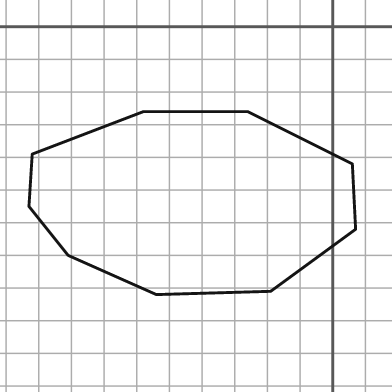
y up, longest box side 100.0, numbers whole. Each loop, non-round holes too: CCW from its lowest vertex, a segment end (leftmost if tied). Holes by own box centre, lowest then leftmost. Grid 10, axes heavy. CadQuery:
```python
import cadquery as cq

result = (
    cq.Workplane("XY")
    .moveTo(-54.0, -82.0)
    .lineTo(-19.0, -81.0)
    .lineTo(7.0, -62.0)
    .lineTo(6.0, -42.0)
    .lineTo(-26.0, -26.0)
    .lineTo(-58.0, -26.0)
    .lineTo(-92.0, -39.0)
    .lineTo(-93.0, -55.0)
    .lineTo(-81.0, -70.0)
    .close()
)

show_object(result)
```